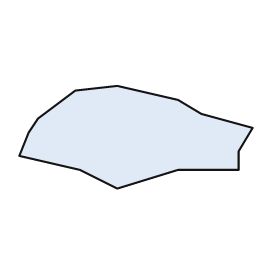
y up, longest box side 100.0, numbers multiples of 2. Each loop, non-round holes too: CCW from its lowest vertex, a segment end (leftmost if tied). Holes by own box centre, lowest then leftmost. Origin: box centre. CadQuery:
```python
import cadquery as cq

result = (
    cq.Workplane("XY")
    .moveTo(-8.0, -22.0)
    .lineTo(18.0, -14.0)
    .lineTo(44.0, -14.0)
    .lineTo(44.0, -6.0)
    .lineTo(50.0, 4.0)
    .lineTo(28.0, 10.0)
    .lineTo(18.0, 16.0)
    .lineTo(-8.0, 22.0)
    .lineTo(-26.0, 20.0)
    .lineTo(-42.0, 8.0)
    .lineTo(-46.0, 2.0)
    .lineTo(-50.0, -8.0)
    .lineTo(-24.0, -14.0)
    .close()
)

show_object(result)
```